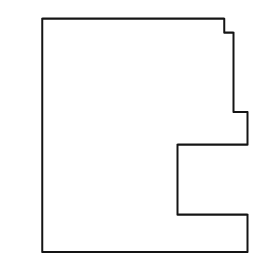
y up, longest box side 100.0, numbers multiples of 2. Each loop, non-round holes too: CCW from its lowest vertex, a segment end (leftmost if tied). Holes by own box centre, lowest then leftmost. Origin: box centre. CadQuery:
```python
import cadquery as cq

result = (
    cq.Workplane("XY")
    .moveTo(-44.0, -50.0)
    .lineTo(44.0, -50.0)
    .lineTo(44.0, -34.0)
    .lineTo(14.0, -34.0)
    .lineTo(14.0, -4.0)
    .lineTo(44.0, -4.0)
    .lineTo(44.0, 10.0)
    .lineTo(38.0, 10.0)
    .lineTo(38.0, 44.0)
    .lineTo(34.0, 44.0)
    .lineTo(34.0, 50.0)
    .lineTo(-44.0, 50.0)
    .close()
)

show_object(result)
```